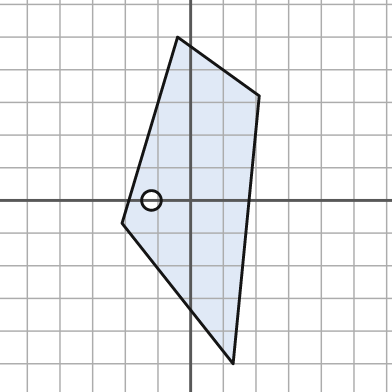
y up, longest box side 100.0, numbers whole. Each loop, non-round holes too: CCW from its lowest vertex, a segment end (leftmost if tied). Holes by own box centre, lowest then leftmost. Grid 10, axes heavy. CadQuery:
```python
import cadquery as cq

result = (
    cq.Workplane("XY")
    .moveTo(13.0, -50.0)
    .lineTo(21.0, 32.0)
    .lineTo(-4.0, 50.0)
    .lineTo(-21.0, -7.0)
    .close()
    .moveTo(-12.0, 0.0)
    .circle(3.0)
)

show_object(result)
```